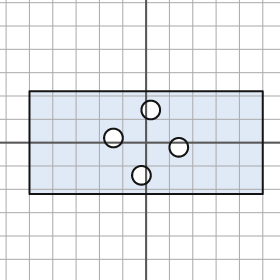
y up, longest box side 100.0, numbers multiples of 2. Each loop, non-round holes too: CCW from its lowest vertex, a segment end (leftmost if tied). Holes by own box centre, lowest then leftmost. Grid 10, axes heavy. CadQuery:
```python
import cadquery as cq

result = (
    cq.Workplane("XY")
    .moveTo(-50.0, -22.0)
    .lineTo(50.0, -22.0)
    .lineTo(50.0, 22.0)
    .lineTo(-50.0, 22.0)
    .close()
    .moveTo(-2.0, -14.0)
    .circle(4.0)
    .moveTo(14.0, -2.0)
    .circle(4.0)
    .moveTo(-14.0, 2.0)
    .circle(4.0)
    .moveTo(2.0, 14.0)
    .circle(4.0)
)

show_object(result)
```